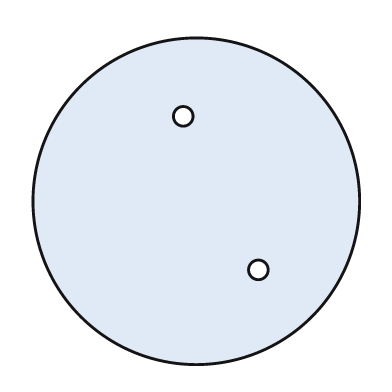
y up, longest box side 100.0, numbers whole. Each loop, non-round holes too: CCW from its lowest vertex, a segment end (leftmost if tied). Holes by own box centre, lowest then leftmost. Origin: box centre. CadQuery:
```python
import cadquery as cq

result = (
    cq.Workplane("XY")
    .moveTo(0.0, 0.0)
    .circle(50.0)
    .moveTo(19.0, -21.0)
    .circle(3.0)
    .moveTo(-4.0, 26.0)
    .circle(3.0)
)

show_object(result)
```